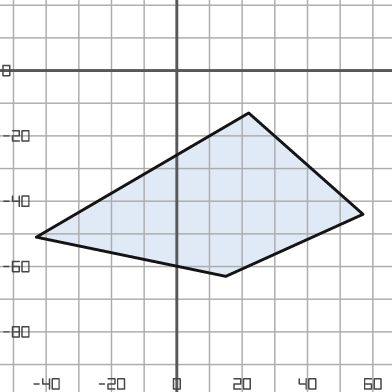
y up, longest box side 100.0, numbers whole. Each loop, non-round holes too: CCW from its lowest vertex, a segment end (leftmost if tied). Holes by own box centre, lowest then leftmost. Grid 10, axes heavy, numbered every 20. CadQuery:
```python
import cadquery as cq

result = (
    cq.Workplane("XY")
    .moveTo(15.0, -63.0)
    .lineTo(57.0, -44.0)
    .lineTo(22.0, -13.0)
    .lineTo(-43.0, -51.0)
    .close()
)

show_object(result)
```